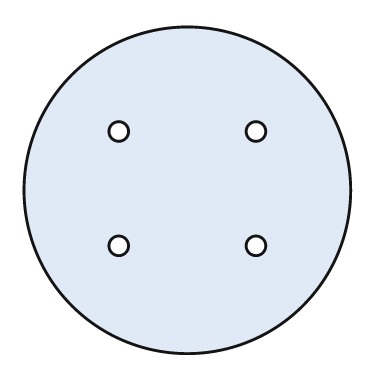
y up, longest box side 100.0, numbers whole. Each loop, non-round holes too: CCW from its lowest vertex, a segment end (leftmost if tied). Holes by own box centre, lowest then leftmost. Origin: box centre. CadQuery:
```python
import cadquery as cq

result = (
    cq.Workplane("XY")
    .moveTo(0.0, 0.0)
    .circle(50.0)
    .moveTo(-21.0, -17.0)
    .circle(3.0)
    .moveTo(21.0, -17.0)
    .circle(3.0)
    .moveTo(-21.0, 18.0)
    .circle(3.0)
    .moveTo(21.0, 18.0)
    .circle(3.0)
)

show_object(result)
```